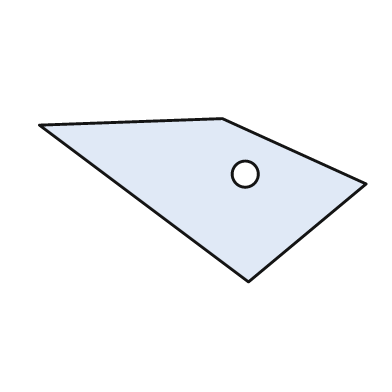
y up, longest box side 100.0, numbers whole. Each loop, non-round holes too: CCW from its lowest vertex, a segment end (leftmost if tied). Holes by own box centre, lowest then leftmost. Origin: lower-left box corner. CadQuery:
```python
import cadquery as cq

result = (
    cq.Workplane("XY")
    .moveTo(64.0, 0.0)
    .lineTo(100.0, 30.0)
    .lineTo(56.0, 50.0)
    .lineTo(0.0, 48.0)
    .close()
    .moveTo(63.0, 33.0)
    .circle(4.0)
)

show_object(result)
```